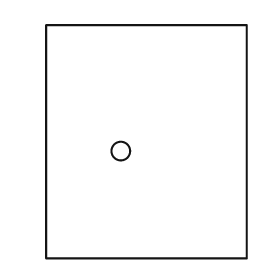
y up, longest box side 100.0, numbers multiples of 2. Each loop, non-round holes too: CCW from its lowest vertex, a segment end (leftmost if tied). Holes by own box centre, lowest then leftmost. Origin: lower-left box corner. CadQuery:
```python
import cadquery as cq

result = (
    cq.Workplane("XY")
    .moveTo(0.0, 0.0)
    .lineTo(86.0, 0.0)
    .lineTo(86.0, 100.0)
    .lineTo(0.0, 100.0)
    .close()
    .moveTo(32.0, 46.0)
    .circle(4.0)
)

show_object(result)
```